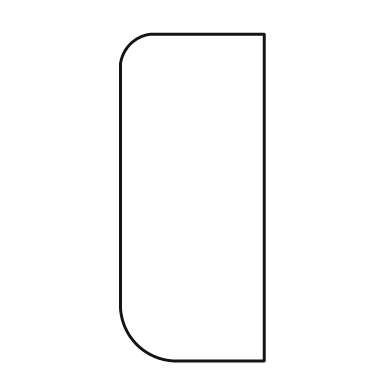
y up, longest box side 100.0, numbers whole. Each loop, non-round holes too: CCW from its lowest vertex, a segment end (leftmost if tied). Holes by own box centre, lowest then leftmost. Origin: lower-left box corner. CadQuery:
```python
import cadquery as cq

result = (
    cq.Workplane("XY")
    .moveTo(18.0, 0.0)
    .lineTo(44.0, 0.0)
    .lineTo(44.0, 100.0)
    .lineTo(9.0, 100.0)
    .threePointArc((3.0, 97.0), (0.0, 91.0))
    .lineTo(0.0, 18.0)
    .threePointArc((5.0, 5.0), (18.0, 0.0))
    .close()
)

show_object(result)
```